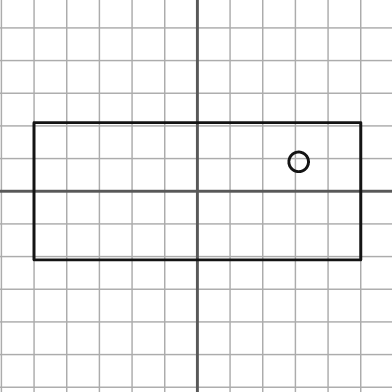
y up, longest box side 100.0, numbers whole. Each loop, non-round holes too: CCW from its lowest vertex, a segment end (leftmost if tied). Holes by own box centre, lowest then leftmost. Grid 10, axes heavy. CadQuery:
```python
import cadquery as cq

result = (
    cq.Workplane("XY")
    .moveTo(-50.0, -21.0)
    .lineTo(50.0, -21.0)
    .lineTo(50.0, 21.0)
    .lineTo(-50.0, 21.0)
    .close()
    .moveTo(31.0, 9.0)
    .circle(3.0)
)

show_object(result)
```